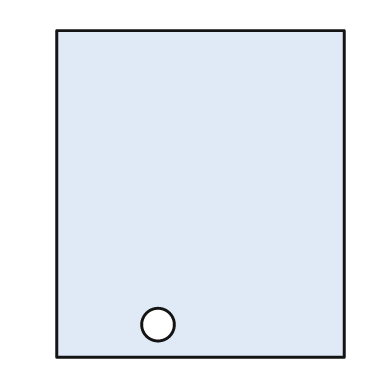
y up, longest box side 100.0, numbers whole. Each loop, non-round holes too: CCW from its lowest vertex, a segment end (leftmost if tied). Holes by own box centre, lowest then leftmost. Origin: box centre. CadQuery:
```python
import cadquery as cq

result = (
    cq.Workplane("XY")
    .moveTo(-44.0, -50.0)
    .lineTo(44.0, -50.0)
    .lineTo(44.0, 50.0)
    .lineTo(-44.0, 50.0)
    .close()
    .moveTo(-13.0, -40.0)
    .circle(5.0)
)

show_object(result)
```